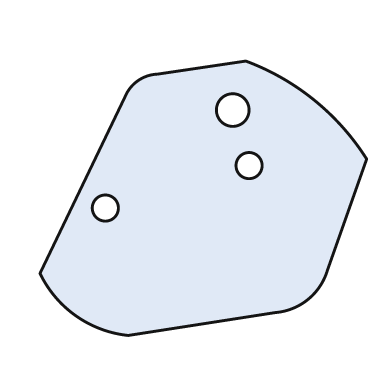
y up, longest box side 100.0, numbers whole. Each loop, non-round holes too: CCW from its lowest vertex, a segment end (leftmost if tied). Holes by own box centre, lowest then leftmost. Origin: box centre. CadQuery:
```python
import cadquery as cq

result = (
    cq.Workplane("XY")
    .moveTo(-23.0, -42.0)
    .lineTo(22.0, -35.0)
    .threePointArc((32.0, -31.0), (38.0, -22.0))
    .lineTo(50.0, 12.0)
    .threePointArc((34.0, 30.0), (13.0, 42.0))
    .lineTo(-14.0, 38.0)
    .threePointArc((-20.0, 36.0), (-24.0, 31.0))
    .lineTo(-50.0, -23.0)
    .threePointArc((-39.0, -36.0), (-23.0, -42.0))
    .close()
    .moveTo(-30.0, -3.0)
    .circle(4.0)
    .moveTo(14.0, 10.0)
    .circle(4.0)
    .moveTo(9.0, 27.0)
    .circle(5.0)
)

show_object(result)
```